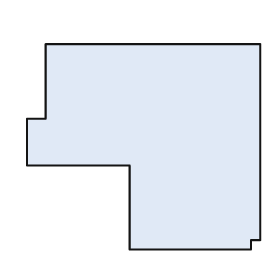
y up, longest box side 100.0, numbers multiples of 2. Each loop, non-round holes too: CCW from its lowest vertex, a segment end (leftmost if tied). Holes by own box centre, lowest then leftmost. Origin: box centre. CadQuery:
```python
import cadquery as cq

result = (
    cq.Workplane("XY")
    .moveTo(-6.0, -44.0)
    .lineTo(46.0, -44.0)
    .lineTo(46.0, -40.0)
    .lineTo(50.0, -40.0)
    .lineTo(50.0, 44.0)
    .lineTo(-42.0, 44.0)
    .lineTo(-42.0, 12.0)
    .lineTo(-50.0, 12.0)
    .lineTo(-50.0, -8.0)
    .lineTo(-6.0, -8.0)
    .close()
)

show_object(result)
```